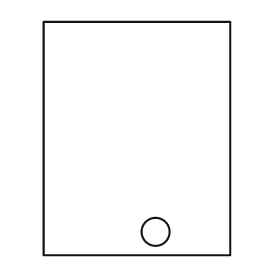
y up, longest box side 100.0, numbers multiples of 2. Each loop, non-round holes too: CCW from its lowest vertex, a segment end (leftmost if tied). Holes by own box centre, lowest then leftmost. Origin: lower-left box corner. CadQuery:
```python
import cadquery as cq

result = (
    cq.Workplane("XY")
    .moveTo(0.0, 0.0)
    .lineTo(80.0, 0.0)
    .lineTo(80.0, 100.0)
    .lineTo(0.0, 100.0)
    .close()
    .moveTo(48.0, 10.0)
    .circle(6.0)
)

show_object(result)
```